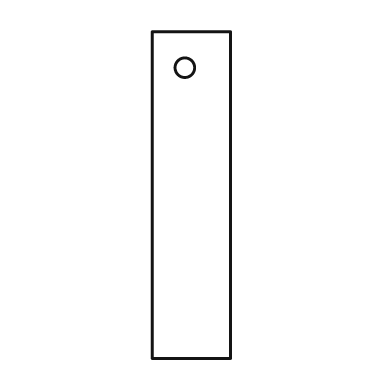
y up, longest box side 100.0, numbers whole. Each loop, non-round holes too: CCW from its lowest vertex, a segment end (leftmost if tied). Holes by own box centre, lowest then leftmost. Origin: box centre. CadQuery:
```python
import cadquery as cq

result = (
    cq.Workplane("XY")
    .moveTo(-12.0, -50.0)
    .lineTo(12.0, -50.0)
    .lineTo(12.0, 50.0)
    .lineTo(-12.0, 50.0)
    .close()
    .moveTo(-2.0, 39.0)
    .circle(3.0)
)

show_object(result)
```